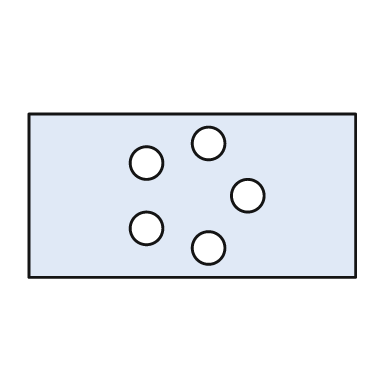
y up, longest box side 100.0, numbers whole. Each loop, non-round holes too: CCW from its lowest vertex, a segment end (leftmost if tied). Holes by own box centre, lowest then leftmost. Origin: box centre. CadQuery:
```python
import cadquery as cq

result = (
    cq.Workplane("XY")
    .moveTo(-50.0, -25.0)
    .lineTo(50.0, -25.0)
    .lineTo(50.0, 25.0)
    .lineTo(-50.0, 25.0)
    .close()
    .moveTo(5.0, -16.0)
    .circle(5.0)
    .moveTo(-14.0, -10.0)
    .circle(5.0)
    .moveTo(17.0, 0.0)
    .circle(5.0)
    .moveTo(-14.0, 10.0)
    .circle(5.0)
    .moveTo(5.0, 16.0)
    .circle(5.0)
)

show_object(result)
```